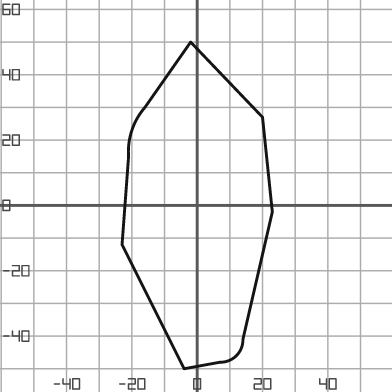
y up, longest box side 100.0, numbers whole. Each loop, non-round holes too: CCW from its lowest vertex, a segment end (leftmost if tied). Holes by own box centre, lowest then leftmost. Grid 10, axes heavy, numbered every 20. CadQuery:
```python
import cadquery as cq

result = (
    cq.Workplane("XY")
    .moveTo(-4.0, -50.0)
    .lineTo(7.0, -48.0)
    .threePointArc((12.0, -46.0), (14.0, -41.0))
    .lineTo(23.0, -2.0)
    .lineTo(20.0, 27.0)
    .lineTo(-2.0, 50.0)
    .lineTo(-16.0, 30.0)
    .threePointArc((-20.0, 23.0), (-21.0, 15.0))
    .lineTo(-23.0, -12.0)
    .close()
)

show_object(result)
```